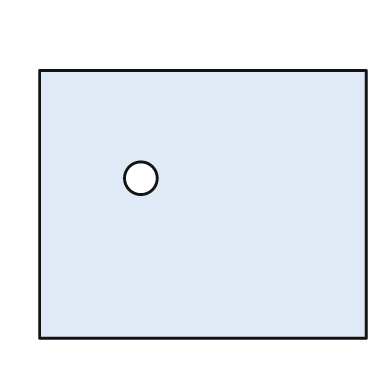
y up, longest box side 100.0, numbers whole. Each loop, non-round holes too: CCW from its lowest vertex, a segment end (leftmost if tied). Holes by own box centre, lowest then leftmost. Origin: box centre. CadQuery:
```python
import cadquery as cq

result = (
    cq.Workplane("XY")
    .moveTo(-50.0, -41.0)
    .lineTo(50.0, -41.0)
    .lineTo(50.0, 41.0)
    .lineTo(-50.0, 41.0)
    .close()
    .moveTo(-19.0, 8.0)
    .circle(5.0)
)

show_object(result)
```